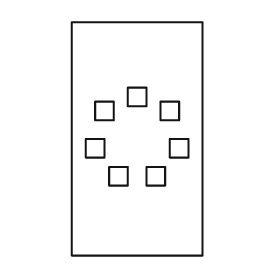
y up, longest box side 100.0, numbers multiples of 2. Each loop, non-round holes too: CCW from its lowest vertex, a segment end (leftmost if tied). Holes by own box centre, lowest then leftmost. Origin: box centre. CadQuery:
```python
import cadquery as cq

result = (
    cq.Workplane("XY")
    .moveTo(-28.0, -50.0)
    .lineTo(28.0, -50.0)
    .lineTo(28.0, 50.0)
    .lineTo(-28.0, 50.0)
    .close()
    .moveTo(-12.0, -20.0)
    .lineTo(-4.0, -20.0)
    .lineTo(-4.0, -12.0)
    .lineTo(-12.0, -12.0)
    .close()
    .moveTo(4.0, -20.0)
    .lineTo(12.0, -20.0)
    .lineTo(12.0, -12.0)
    .lineTo(4.0, -12.0)
    .close()
    .moveTo(-22.0, -8.0)
    .lineTo(-14.0, -8.0)
    .lineTo(-14.0, 0.0)
    .lineTo(-22.0, 0.0)
    .close()
    .moveTo(14.0, -8.0)
    .lineTo(22.0, -8.0)
    .lineTo(22.0, 0.0)
    .lineTo(14.0, 0.0)
    .close()
    .moveTo(-18.0, 8.0)
    .lineTo(-10.0, 8.0)
    .lineTo(-10.0, 16.0)
    .lineTo(-18.0, 16.0)
    .close()
    .moveTo(10.0, 8.0)
    .lineTo(18.0, 8.0)
    .lineTo(18.0, 16.0)
    .lineTo(10.0, 16.0)
    .close()
    .moveTo(-4.0, 14.0)
    .lineTo(4.0, 14.0)
    .lineTo(4.0, 22.0)
    .lineTo(-4.0, 22.0)
    .close()
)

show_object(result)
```